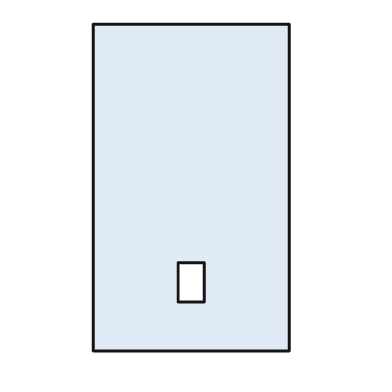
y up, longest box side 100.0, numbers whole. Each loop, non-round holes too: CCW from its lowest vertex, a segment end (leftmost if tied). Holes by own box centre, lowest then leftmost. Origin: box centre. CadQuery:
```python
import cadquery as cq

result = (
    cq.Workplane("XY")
    .moveTo(-30.0, -50.0)
    .lineTo(30.0, -50.0)
    .lineTo(30.0, 50.0)
    .lineTo(-30.0, 50.0)
    .close()
    .moveTo(-4.0, -35.0)
    .lineTo(4.0, -35.0)
    .lineTo(4.0, -23.0)
    .lineTo(-4.0, -23.0)
    .close()
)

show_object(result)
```